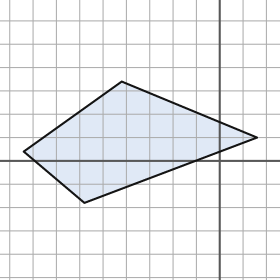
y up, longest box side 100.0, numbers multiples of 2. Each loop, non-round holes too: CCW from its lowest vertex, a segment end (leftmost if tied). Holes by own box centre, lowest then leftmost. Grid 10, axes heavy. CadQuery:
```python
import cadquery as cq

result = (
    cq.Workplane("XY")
    .moveTo(-58.0, -18.0)
    .lineTo(16.0, 10.0)
    .lineTo(-42.0, 34.0)
    .lineTo(-84.0, 4.0)
    .close()
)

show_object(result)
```